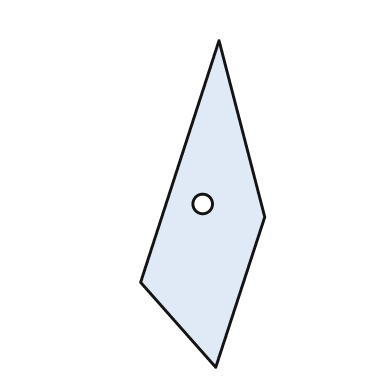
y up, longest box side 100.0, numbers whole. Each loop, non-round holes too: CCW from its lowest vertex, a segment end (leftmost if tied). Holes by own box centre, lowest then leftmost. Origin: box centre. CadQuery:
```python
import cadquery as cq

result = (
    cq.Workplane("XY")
    .moveTo(4.0, -50.0)
    .lineTo(19.0, -4.0)
    .lineTo(5.0, 50.0)
    .lineTo(-19.0, -24.0)
    .close()
    .moveTo(0.0, 0.0)
    .circle(3.0)
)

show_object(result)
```